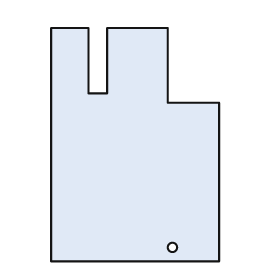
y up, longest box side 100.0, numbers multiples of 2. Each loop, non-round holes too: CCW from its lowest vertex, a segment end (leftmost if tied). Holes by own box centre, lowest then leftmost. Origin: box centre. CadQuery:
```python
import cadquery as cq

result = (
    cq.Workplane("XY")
    .moveTo(-36.0, -50.0)
    .lineTo(36.0, -50.0)
    .lineTo(36.0, 18.0)
    .lineTo(14.0, 18.0)
    .lineTo(14.0, 50.0)
    .lineTo(-12.0, 50.0)
    .lineTo(-12.0, 22.0)
    .lineTo(-20.0, 22.0)
    .lineTo(-20.0, 50.0)
    .lineTo(-36.0, 50.0)
    .close()
    .moveTo(16.0, -44.0)
    .circle(2.0)
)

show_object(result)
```